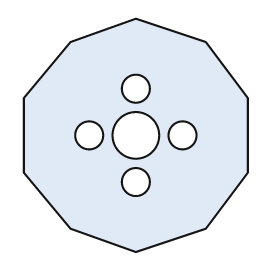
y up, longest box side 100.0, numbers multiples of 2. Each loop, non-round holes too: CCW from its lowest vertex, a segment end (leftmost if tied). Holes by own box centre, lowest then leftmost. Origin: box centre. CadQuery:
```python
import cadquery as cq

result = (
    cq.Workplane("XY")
    .moveTo(0.0, -50.0)
    .lineTo(30.0, -40.0)
    .lineTo(48.0, -16.0)
    .lineTo(48.0, 16.0)
    .lineTo(30.0, 40.0)
    .lineTo(0.0, 50.0)
    .lineTo(-28.0, 40.0)
    .lineTo(-48.0, 16.0)
    .lineTo(-48.0, -16.0)
    .lineTo(-28.0, -40.0)
    .close()
    .moveTo(0.0, -20.0)
    .circle(6.0)
    .moveTo(-20.0, 0.0)
    .circle(6.0)
    .moveTo(0.0, 0.0)
    .circle(10.0)
    .moveTo(20.0, 0.0)
    .circle(6.0)
    .moveTo(0.0, 20.0)
    .circle(6.0)
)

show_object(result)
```